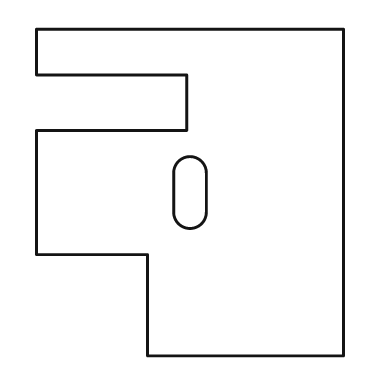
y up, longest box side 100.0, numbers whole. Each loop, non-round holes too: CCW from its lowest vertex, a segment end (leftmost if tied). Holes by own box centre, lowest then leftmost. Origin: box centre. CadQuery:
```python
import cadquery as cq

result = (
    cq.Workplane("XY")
    .moveTo(-13.0, -50.0)
    .lineTo(47.0, -50.0)
    .lineTo(47.0, 50.0)
    .lineTo(-47.0, 50.0)
    .lineTo(-47.0, 36.0)
    .lineTo(-1.0, 36.0)
    .lineTo(-1.0, 19.0)
    .lineTo(-47.0, 19.0)
    .lineTo(-47.0, -19.0)
    .lineTo(-13.0, -19.0)
    .close()
    .moveTo(-5.0, -6.0)
    .threePointArc((0.0, -11.0), (5.0, -6.0))
    .lineTo(5.0, 6.0)
    .threePointArc((0.0, 11.0), (-5.0, 6.0))
    .close()
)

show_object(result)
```